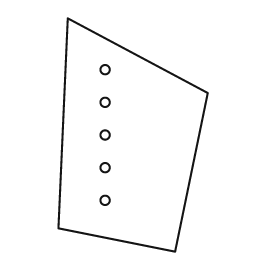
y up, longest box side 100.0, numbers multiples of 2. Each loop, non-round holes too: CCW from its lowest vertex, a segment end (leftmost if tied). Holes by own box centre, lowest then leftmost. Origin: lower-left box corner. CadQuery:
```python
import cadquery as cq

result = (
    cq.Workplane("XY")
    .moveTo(50.0, 0.0)
    .lineTo(64.0, 68.0)
    .lineTo(4.0, 100.0)
    .lineTo(0.0, 10.0)
    .close()
    .moveTo(20.0, 22.0)
    .circle(2.0)
    .moveTo(20.0, 36.0)
    .circle(2.0)
    .moveTo(20.0, 50.0)
    .circle(2.0)
    .moveTo(20.0, 64.0)
    .circle(2.0)
    .moveTo(20.0, 78.0)
    .circle(2.0)
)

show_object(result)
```